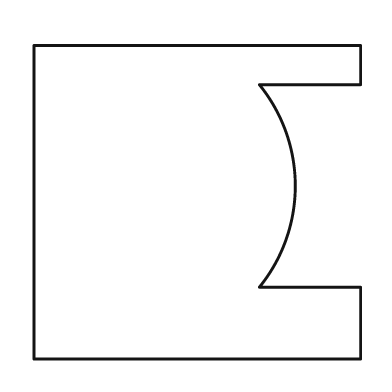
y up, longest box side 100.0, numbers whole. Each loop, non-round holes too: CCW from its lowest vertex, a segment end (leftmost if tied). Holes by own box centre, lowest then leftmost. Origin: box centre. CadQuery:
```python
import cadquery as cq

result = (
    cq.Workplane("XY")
    .moveTo(-50.0, -48.0)
    .lineTo(50.0, -48.0)
    .lineTo(50.0, -26.0)
    .lineTo(19.0, -26.0)
    .threePointArc((30.0, 5.0), (19.0, 36.0))
    .lineTo(50.0, 36.0)
    .lineTo(50.0, 48.0)
    .lineTo(-50.0, 48.0)
    .close()
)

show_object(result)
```